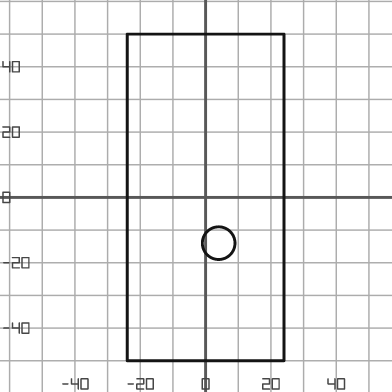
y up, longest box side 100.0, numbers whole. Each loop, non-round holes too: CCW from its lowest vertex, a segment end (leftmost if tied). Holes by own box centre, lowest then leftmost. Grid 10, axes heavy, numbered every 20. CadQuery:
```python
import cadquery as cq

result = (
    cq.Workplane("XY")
    .moveTo(-24.0, -50.0)
    .lineTo(24.0, -50.0)
    .lineTo(24.0, 50.0)
    .lineTo(-24.0, 50.0)
    .close()
    .moveTo(4.0, -14.0)
    .circle(5.0)
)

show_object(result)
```